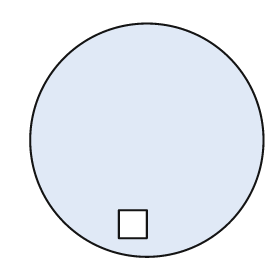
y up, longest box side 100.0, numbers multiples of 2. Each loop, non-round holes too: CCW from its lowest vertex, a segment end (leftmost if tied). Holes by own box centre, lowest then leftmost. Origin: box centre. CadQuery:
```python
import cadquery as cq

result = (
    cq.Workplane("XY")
    .moveTo(0.0, 0.0)
    .circle(50.0)
    .moveTo(-12.0, -42.0)
    .lineTo(0.0, -42.0)
    .lineTo(0.0, -30.0)
    .lineTo(-12.0, -30.0)
    .close()
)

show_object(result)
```